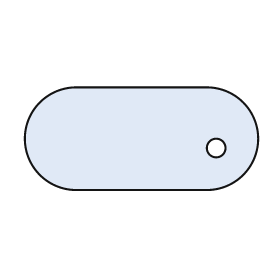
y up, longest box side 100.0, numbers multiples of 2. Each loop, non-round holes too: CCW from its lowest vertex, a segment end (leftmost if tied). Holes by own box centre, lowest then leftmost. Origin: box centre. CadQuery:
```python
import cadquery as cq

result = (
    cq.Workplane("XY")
    .moveTo(-28.0, -22.0)
    .lineTo(28.0, -22.0)
    .threePointArc((50.0, 0.0), (28.0, 22.0))
    .lineTo(-28.0, 22.0)
    .threePointArc((-50.0, 0.0), (-28.0, -22.0))
    .close()
    .moveTo(32.0, -4.0)
    .circle(4.0)
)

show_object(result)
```